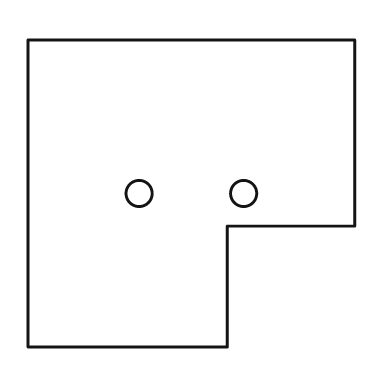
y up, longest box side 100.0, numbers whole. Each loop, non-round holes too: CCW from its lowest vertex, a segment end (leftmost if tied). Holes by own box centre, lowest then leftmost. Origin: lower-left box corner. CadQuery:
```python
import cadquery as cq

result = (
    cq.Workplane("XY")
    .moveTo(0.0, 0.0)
    .lineTo(61.0, 0.0)
    .lineTo(61.0, 37.0)
    .lineTo(100.0, 37.0)
    .lineTo(100.0, 94.0)
    .lineTo(0.0, 94.0)
    .close()
    .moveTo(34.0, 47.0)
    .circle(4.0)
    .moveTo(66.0, 47.0)
    .circle(4.0)
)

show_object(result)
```